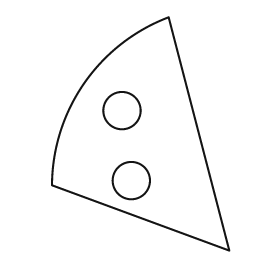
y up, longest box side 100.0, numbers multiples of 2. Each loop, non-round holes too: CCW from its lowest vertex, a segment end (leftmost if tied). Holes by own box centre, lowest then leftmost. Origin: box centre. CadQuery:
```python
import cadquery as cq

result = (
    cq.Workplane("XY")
    .moveTo(38.0, -50.0)
    .lineTo(12.0, 50.0)
    .threePointArc((-24.0, 22.0), (-38.0, -22.0))
    .close()
    .moveTo(-4.0, -20.0)
    .circle(8.0)
    .moveTo(-8.0, 10.0)
    .circle(8.0)
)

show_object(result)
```